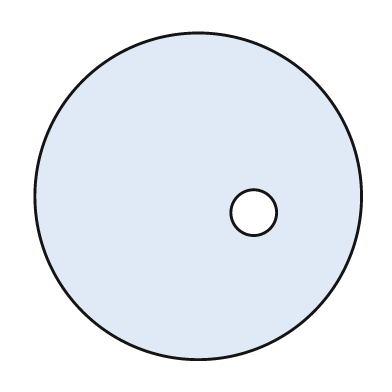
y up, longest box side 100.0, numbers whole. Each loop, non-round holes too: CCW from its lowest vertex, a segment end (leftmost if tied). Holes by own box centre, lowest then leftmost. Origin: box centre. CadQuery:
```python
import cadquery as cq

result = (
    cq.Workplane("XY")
    .moveTo(0.0, 0.0)
    .circle(50.0)
    .moveTo(17.0, -5.0)
    .circle(7.0)
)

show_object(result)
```